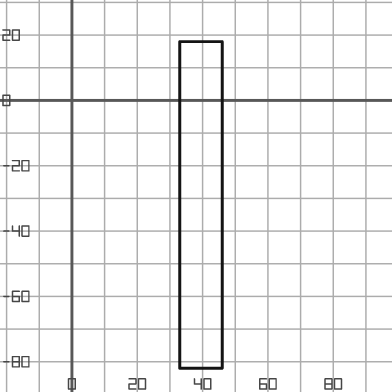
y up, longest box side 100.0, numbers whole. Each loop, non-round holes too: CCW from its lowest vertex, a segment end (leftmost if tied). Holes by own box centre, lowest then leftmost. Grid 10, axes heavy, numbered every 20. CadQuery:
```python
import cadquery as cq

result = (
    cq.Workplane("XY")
    .moveTo(33.0, -82.0)
    .lineTo(46.0, -82.0)
    .lineTo(46.0, 18.0)
    .lineTo(33.0, 18.0)
    .close()
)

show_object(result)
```